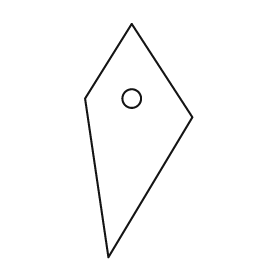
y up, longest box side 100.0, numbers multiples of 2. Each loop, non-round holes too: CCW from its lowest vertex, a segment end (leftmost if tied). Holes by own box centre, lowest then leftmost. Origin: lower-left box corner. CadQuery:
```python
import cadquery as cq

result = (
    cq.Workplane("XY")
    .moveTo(10.0, 0.0)
    .lineTo(46.0, 60.0)
    .lineTo(20.0, 100.0)
    .lineTo(0.0, 68.0)
    .close()
    .moveTo(20.0, 68.0)
    .circle(4.0)
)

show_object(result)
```